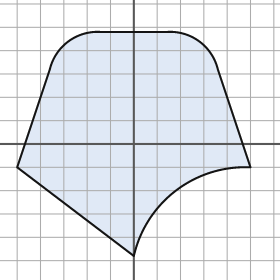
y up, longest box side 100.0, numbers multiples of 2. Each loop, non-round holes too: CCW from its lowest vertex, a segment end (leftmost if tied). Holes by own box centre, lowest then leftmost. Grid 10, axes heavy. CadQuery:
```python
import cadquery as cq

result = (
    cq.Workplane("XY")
    .moveTo(0.0, -48.0)
    .threePointArc((18.0, -20.0), (50.0, -10.0))
    .lineTo(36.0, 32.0)
    .threePointArc((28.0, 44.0), (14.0, 48.0))
    .lineTo(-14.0, 48.0)
    .threePointArc((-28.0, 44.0), (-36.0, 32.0))
    .lineTo(-50.0, -10.0)
    .close()
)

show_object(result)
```